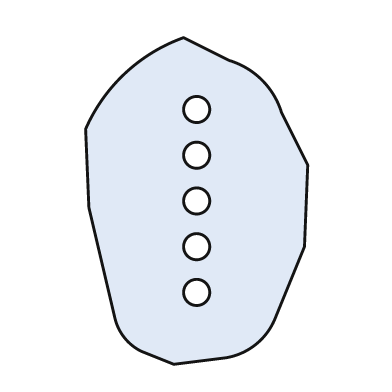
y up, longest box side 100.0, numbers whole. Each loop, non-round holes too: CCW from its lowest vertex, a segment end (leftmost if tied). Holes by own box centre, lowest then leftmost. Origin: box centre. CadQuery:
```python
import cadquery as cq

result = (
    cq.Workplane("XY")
    .moveTo(-7.0, -50.0)
    .lineTo(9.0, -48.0)
    .threePointArc((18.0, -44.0), (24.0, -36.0))
    .lineTo(33.0, -14.0)
    .lineTo(34.0, 11.0)
    .lineTo(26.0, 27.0)
    .threePointArc((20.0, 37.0), (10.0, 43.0))
    .lineTo(-4.0, 50.0)
    .threePointArc((-22.0, 39.0), (-34.0, 22.0))
    .lineTo(-33.0, -2.0)
    .lineTo(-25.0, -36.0)
    .threePointArc((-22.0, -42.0), (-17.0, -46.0))
    .close()
    .moveTo(0.0, -28.0)
    .circle(4.0)
    .moveTo(0.0, -14.0)
    .circle(4.0)
    .moveTo(0.0, 0.0)
    .circle(4.0)
    .moveTo(0.0, 14.0)
    .circle(4.0)
    .moveTo(0.0, 28.0)
    .circle(4.0)
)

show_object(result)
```